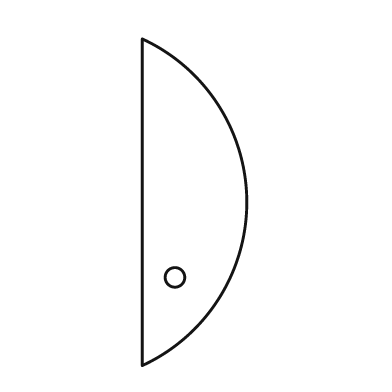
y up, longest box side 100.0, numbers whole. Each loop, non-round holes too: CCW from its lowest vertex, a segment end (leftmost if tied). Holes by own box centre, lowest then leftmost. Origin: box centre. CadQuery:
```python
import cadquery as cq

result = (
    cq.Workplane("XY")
    .moveTo(-16.0, -50.0)
    .threePointArc((16.0, 0.0), (-16.0, 50.0))
    .close()
    .moveTo(-6.0, -23.0)
    .circle(3.0)
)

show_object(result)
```